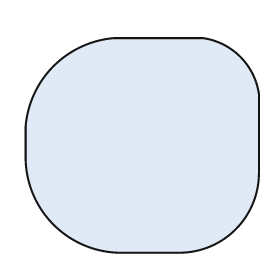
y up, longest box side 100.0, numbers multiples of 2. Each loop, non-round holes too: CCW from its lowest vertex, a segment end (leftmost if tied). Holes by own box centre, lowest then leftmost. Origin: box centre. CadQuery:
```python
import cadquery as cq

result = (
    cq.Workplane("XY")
    .moveTo(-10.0, -46.0)
    .lineTo(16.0, -46.0)
    .threePointArc((40.0, -36.0), (50.0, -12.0))
    .lineTo(50.0, 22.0)
    .threePointArc((42.0, 38.0), (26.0, 46.0))
    .lineTo(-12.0, 46.0)
    .threePointArc((-38.0, 34.0), (-50.0, 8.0))
    .lineTo(-50.0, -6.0)
    .threePointArc((-38.0, -34.0), (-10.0, -46.0))
    .close()
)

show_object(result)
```